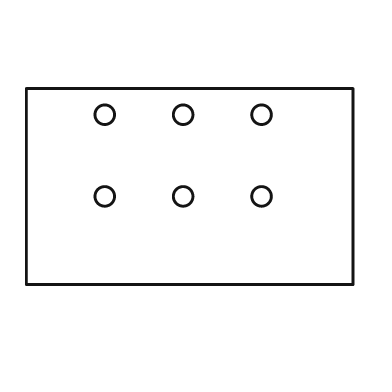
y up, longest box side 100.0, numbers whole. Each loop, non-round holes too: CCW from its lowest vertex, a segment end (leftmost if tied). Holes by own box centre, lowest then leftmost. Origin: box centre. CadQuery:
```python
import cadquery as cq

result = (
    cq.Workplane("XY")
    .moveTo(-50.0, -30.0)
    .lineTo(50.0, -30.0)
    .lineTo(50.0, 30.0)
    .lineTo(-50.0, 30.0)
    .close()
    .moveTo(-26.0, -3.0)
    .circle(3.0)
    .moveTo(-2.0, -3.0)
    .circle(3.0)
    .moveTo(22.0, -3.0)
    .circle(3.0)
    .moveTo(-26.0, 22.0)
    .circle(3.0)
    .moveTo(-2.0, 22.0)
    .circle(3.0)
    .moveTo(22.0, 22.0)
    .circle(3.0)
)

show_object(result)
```